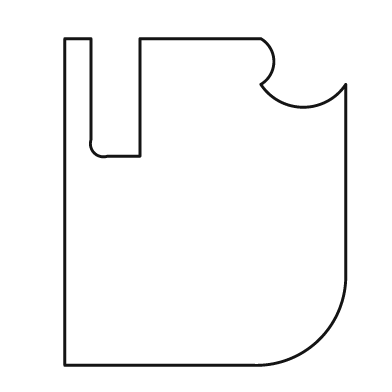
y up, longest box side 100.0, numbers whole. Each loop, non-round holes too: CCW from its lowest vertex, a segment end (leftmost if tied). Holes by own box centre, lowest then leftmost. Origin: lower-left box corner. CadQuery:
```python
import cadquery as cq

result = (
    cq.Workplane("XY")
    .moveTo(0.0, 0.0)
    .lineTo(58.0, 0.0)
    .threePointArc((78.0, 8.0), (86.0, 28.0))
    .lineTo(86.0, 86.0)
    .threePointArc((73.0, 79.0), (60.0, 86.0))
    .threePointArc((64.0, 93.0), (60.0, 100.0))
    .lineTo(23.0, 100.0)
    .lineTo(23.0, 64.0)
    .lineTo(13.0, 64.0)
    .threePointArc((9.0, 65.0), (8.0, 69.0))
    .lineTo(8.0, 100.0)
    .lineTo(0.0, 100.0)
    .close()
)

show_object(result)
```